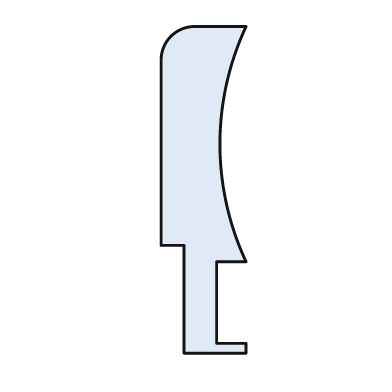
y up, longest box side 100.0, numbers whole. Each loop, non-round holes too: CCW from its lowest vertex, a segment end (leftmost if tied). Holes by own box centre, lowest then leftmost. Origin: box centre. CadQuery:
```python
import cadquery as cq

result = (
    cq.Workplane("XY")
    .moveTo(-6.0, -50.0)
    .lineTo(13.0, -50.0)
    .lineTo(13.0, -47.0)
    .lineTo(4.0, -47.0)
    .lineTo(4.0, -22.0)
    .lineTo(13.0, -22.0)
    .threePointArc((5.0, 14.0), (13.0, 50.0))
    .lineTo(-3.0, 50.0)
    .threePointArc((-10.0, 47.0), (-13.0, 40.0))
    .lineTo(-13.0, -17.0)
    .lineTo(-6.0, -17.0)
    .close()
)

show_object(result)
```